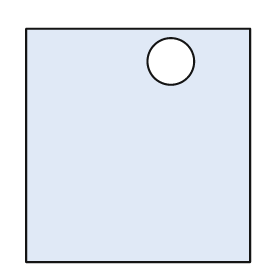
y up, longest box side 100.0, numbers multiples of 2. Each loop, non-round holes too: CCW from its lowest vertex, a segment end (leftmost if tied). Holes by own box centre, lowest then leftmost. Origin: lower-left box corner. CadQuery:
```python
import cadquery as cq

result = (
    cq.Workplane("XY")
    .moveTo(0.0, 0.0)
    .lineTo(96.0, 0.0)
    .lineTo(96.0, 100.0)
    .lineTo(0.0, 100.0)
    .close()
    .moveTo(62.0, 86.0)
    .circle(10.0)
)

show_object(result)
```